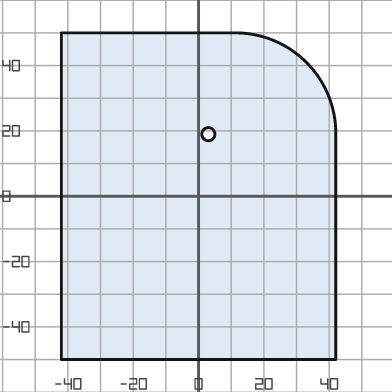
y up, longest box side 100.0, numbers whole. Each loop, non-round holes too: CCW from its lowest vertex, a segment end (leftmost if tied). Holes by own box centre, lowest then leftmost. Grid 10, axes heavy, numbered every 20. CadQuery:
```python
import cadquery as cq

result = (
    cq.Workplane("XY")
    .moveTo(-42.0, -50.0)
    .lineTo(42.0, -50.0)
    .lineTo(42.0, 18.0)
    .threePointArc((33.0, 41.0), (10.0, 50.0))
    .lineTo(-42.0, 50.0)
    .close()
    .moveTo(3.0, 19.0)
    .circle(2.0)
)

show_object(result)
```